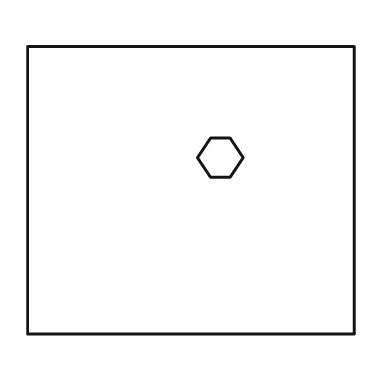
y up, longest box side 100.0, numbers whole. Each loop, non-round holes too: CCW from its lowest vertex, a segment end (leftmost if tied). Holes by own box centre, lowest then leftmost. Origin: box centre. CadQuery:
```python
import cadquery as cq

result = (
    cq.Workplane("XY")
    .moveTo(-50.0, -44.0)
    .lineTo(50.0, -44.0)
    .lineTo(50.0, 44.0)
    .lineTo(-50.0, 44.0)
    .close()
    .moveTo(6.0, 4.0)
    .lineTo(12.0, 4.0)
    .lineTo(16.0, 10.0)
    .lineTo(12.0, 16.0)
    .lineTo(6.0, 16.0)
    .lineTo(2.0, 10.0)
    .close()
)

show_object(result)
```